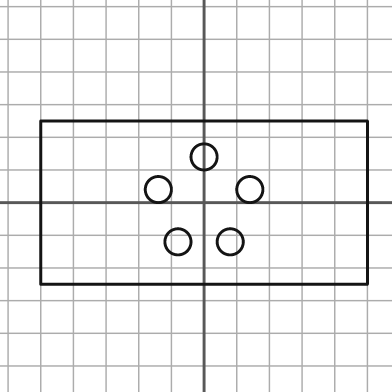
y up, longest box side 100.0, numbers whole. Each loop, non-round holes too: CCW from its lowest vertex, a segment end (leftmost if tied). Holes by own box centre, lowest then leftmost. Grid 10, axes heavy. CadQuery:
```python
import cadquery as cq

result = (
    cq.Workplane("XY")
    .moveTo(-50.0, -25.0)
    .lineTo(50.0, -25.0)
    .lineTo(50.0, 25.0)
    .lineTo(-50.0, 25.0)
    .close()
    .moveTo(-8.0, -12.0)
    .circle(4.0)
    .moveTo(8.0, -12.0)
    .circle(4.0)
    .moveTo(-14.0, 4.0)
    .circle(4.0)
    .moveTo(14.0, 4.0)
    .circle(4.0)
    .moveTo(0.0, 14.0)
    .circle(4.0)
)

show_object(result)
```